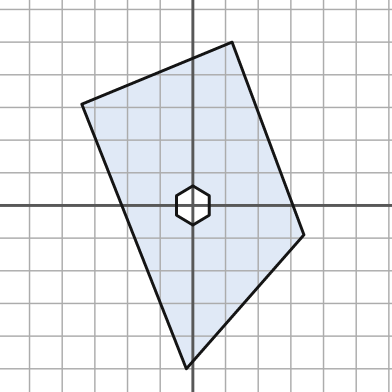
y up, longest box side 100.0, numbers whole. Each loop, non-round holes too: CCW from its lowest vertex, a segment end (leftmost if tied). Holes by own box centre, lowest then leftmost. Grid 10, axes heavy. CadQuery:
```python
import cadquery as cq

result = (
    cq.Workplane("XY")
    .moveTo(-2.0, -50.0)
    .lineTo(34.0, -9.0)
    .lineTo(12.0, 50.0)
    .lineTo(-34.0, 31.0)
    .close()
    .moveTo(0.0, -6.0)
    .lineTo(5.0, -3.0)
    .lineTo(5.0, 3.0)
    .lineTo(0.0, 6.0)
    .lineTo(-5.0, 3.0)
    .lineTo(-5.0, -3.0)
    .close()
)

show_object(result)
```